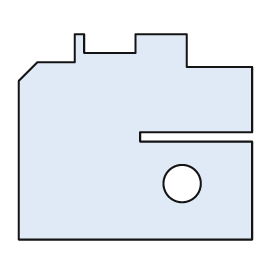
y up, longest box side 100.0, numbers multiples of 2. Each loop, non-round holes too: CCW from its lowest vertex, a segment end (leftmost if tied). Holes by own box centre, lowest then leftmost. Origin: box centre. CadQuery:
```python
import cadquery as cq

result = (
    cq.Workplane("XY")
    .moveTo(-50.0, -44.0)
    .lineTo(50.0, -44.0)
    .lineTo(50.0, -2.0)
    .lineTo(2.0, -2.0)
    .lineTo(2.0, 2.0)
    .lineTo(50.0, 2.0)
    .lineTo(50.0, 30.0)
    .lineTo(22.0, 30.0)
    .lineTo(22.0, 44.0)
    .lineTo(0.0, 44.0)
    .lineTo(0.0, 36.0)
    .lineTo(-22.0, 36.0)
    .lineTo(-22.0, 44.0)
    .lineTo(-26.0, 44.0)
    .lineTo(-26.0, 32.0)
    .lineTo(-42.0, 32.0)
    .lineTo(-50.0, 24.0)
    .close()
    .moveTo(20.0, -20.0)
    .circle(8.0)
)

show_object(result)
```